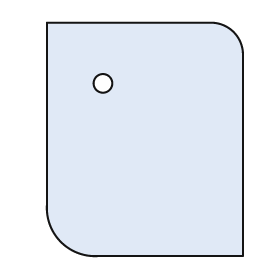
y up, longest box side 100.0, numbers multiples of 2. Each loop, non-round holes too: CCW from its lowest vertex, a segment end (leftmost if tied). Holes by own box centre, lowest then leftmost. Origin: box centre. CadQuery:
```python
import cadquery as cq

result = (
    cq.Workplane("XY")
    .moveTo(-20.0, -50.0)
    .lineTo(42.0, -50.0)
    .lineTo(42.0, 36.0)
    .threePointArc((38.0, 46.0), (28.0, 50.0))
    .lineTo(-42.0, 50.0)
    .lineTo(-42.0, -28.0)
    .threePointArc((-36.0, -44.0), (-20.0, -50.0))
    .close()
    .moveTo(-18.0, 24.0)
    .circle(4.0)
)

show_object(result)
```